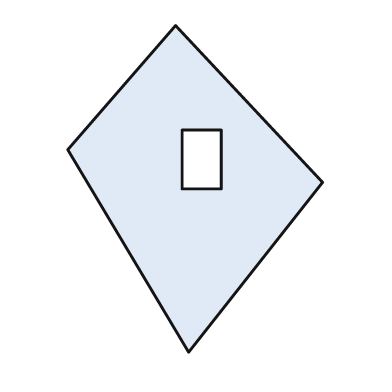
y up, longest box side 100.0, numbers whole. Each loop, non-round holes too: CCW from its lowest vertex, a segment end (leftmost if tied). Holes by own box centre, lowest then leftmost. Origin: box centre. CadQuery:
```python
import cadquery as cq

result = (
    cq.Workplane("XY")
    .moveTo(-2.0, -50.0)
    .lineTo(39.0, 2.0)
    .lineTo(-6.0, 50.0)
    .lineTo(-39.0, 12.0)
    .close()
    .moveTo(-4.0, 0.0)
    .lineTo(8.0, 0.0)
    .lineTo(8.0, 18.0)
    .lineTo(-4.0, 18.0)
    .close()
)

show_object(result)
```